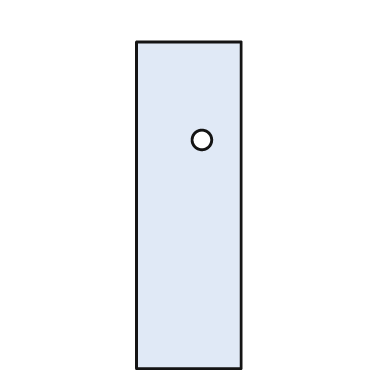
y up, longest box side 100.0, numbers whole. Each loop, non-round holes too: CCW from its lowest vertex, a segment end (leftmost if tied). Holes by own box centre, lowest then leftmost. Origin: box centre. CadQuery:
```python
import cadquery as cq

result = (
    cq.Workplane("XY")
    .moveTo(-16.0, -50.0)
    .lineTo(16.0, -50.0)
    .lineTo(16.0, 50.0)
    .lineTo(-16.0, 50.0)
    .close()
    .moveTo(4.0, 20.0)
    .circle(3.0)
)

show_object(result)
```